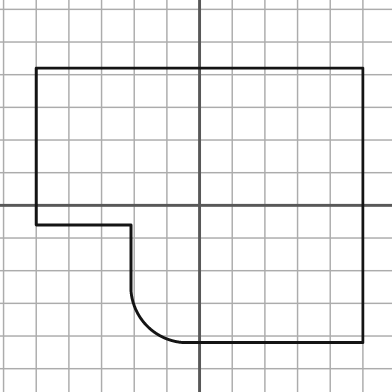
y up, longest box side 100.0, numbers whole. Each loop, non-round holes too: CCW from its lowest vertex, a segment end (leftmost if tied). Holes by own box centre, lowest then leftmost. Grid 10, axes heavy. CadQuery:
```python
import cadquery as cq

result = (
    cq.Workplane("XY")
    .moveTo(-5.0, -42.0)
    .lineTo(50.0, -42.0)
    .lineTo(50.0, 42.0)
    .lineTo(-50.0, 42.0)
    .lineTo(-50.0, -6.0)
    .lineTo(-21.0, -6.0)
    .lineTo(-21.0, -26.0)
    .threePointArc((-16.0, -37.0), (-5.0, -42.0))
    .close()
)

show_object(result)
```